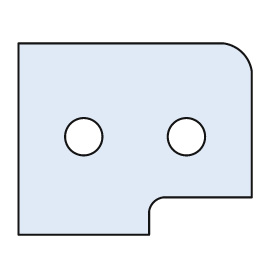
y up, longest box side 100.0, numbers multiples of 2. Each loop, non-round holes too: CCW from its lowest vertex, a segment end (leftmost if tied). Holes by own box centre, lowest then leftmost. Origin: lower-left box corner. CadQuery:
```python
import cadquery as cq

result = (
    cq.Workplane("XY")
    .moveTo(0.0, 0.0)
    .lineTo(56.0, 0.0)
    .lineTo(56.0, 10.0)
    .threePointArc((58.0, 14.0), (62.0, 16.0))
    .lineTo(100.0, 16.0)
    .lineTo(100.0, 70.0)
    .threePointArc((96.0, 78.0), (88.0, 82.0))
    .lineTo(0.0, 82.0)
    .close()
    .moveTo(28.0, 42.0)
    .circle(8.0)
    .moveTo(72.0, 42.0)
    .circle(8.0)
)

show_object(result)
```